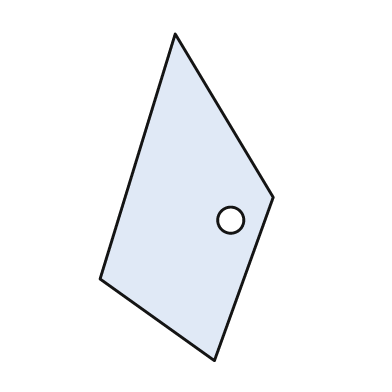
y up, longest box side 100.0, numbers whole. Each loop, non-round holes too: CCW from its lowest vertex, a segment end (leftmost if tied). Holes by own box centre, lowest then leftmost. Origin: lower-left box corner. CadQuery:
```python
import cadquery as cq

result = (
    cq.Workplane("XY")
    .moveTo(35.0, 0.0)
    .lineTo(53.0, 50.0)
    .lineTo(23.0, 100.0)
    .lineTo(0.0, 25.0)
    .close()
    .moveTo(40.0, 43.0)
    .circle(4.0)
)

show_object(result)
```